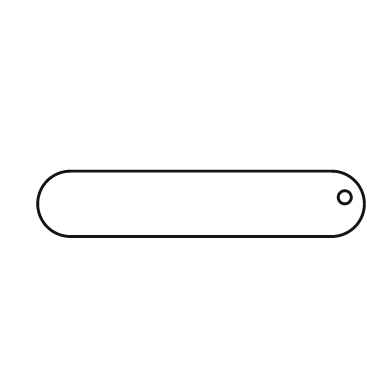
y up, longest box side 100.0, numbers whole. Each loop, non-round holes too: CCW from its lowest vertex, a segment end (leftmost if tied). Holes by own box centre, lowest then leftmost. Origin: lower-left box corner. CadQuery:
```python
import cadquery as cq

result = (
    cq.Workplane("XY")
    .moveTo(10.0, 0.0)
    .lineTo(90.0, 0.0)
    .threePointArc((100.0, 10.0), (90.0, 20.0))
    .lineTo(10.0, 20.0)
    .threePointArc((0.0, 10.0), (10.0, 0.0))
    .close()
    .moveTo(94.0, 12.0)
    .circle(2.0)
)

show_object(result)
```